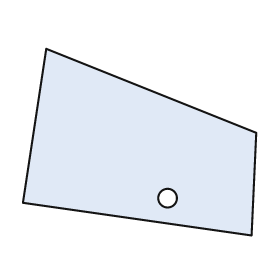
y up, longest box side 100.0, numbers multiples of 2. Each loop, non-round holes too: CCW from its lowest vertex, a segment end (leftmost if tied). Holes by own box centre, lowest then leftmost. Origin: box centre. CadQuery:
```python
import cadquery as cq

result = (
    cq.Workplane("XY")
    .moveTo(48.0, -40.0)
    .lineTo(50.0, 4.0)
    .lineTo(-40.0, 40.0)
    .lineTo(-50.0, -26.0)
    .close()
    .moveTo(12.0, -24.0)
    .circle(4.0)
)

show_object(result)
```